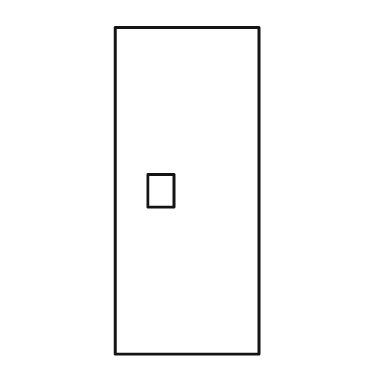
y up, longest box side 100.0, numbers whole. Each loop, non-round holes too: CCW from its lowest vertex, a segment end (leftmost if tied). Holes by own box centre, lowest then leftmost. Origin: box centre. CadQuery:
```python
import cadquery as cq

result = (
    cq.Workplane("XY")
    .moveTo(-22.0, -50.0)
    .lineTo(22.0, -50.0)
    .lineTo(22.0, 50.0)
    .lineTo(-22.0, 50.0)
    .close()
    .moveTo(-12.0, -5.0)
    .lineTo(-4.0, -5.0)
    .lineTo(-4.0, 5.0)
    .lineTo(-12.0, 5.0)
    .close()
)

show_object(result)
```